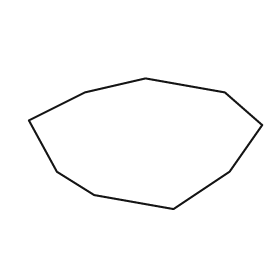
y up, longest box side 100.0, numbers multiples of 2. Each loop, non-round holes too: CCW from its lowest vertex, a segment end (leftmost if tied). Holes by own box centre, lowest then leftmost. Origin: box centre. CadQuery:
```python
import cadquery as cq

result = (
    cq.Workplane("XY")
    .moveTo(12.0, -28.0)
    .lineTo(36.0, -12.0)
    .lineTo(50.0, 8.0)
    .lineTo(34.0, 22.0)
    .lineTo(0.0, 28.0)
    .lineTo(-26.0, 22.0)
    .lineTo(-50.0, 10.0)
    .lineTo(-38.0, -12.0)
    .lineTo(-22.0, -22.0)
    .close()
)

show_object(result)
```